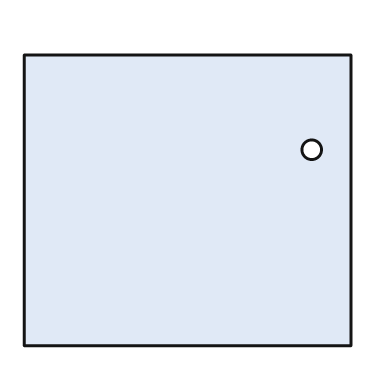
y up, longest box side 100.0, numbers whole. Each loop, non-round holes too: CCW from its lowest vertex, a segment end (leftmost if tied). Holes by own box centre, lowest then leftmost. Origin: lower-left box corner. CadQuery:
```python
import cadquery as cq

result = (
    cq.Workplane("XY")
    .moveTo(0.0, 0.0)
    .lineTo(100.0, 0.0)
    .lineTo(100.0, 89.0)
    .lineTo(0.0, 89.0)
    .close()
    .moveTo(88.0, 60.0)
    .circle(3.0)
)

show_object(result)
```